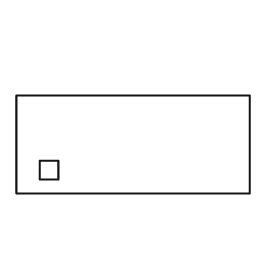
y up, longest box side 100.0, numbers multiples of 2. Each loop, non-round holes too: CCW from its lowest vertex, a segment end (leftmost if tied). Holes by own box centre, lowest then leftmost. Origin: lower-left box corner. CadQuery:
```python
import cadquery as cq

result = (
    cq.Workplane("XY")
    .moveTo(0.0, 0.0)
    .lineTo(100.0, 0.0)
    .lineTo(100.0, 42.0)
    .lineTo(0.0, 42.0)
    .close()
    .moveTo(10.0, 6.0)
    .lineTo(18.0, 6.0)
    .lineTo(18.0, 14.0)
    .lineTo(10.0, 14.0)
    .close()
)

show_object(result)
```